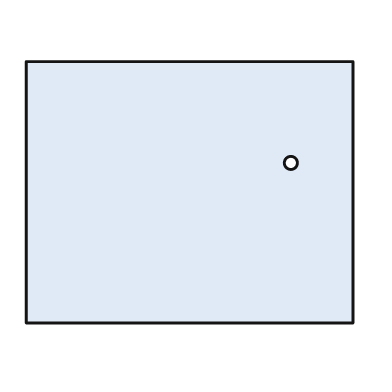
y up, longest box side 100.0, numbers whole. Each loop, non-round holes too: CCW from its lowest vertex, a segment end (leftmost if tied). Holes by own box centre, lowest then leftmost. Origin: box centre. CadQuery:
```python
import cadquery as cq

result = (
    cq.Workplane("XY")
    .moveTo(-50.0, -40.0)
    .lineTo(50.0, -40.0)
    .lineTo(50.0, 40.0)
    .lineTo(-50.0, 40.0)
    .close()
    .moveTo(31.0, 9.0)
    .circle(2.0)
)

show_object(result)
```